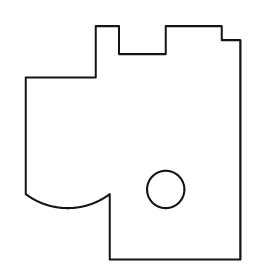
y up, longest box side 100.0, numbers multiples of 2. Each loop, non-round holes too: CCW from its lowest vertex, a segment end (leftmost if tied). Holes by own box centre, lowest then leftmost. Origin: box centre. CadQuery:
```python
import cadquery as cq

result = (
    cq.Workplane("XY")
    .moveTo(-10.0, -50.0)
    .lineTo(46.0, -50.0)
    .lineTo(46.0, 44.0)
    .lineTo(38.0, 44.0)
    .lineTo(38.0, 50.0)
    .lineTo(14.0, 50.0)
    .lineTo(14.0, 38.0)
    .lineTo(-6.0, 38.0)
    .lineTo(-6.0, 50.0)
    .lineTo(-16.0, 50.0)
    .lineTo(-16.0, 28.0)
    .lineTo(-46.0, 28.0)
    .lineTo(-46.0, -22.0)
    .threePointArc((-28.0, -28.0), (-10.0, -22.0))
    .close()
    .moveTo(14.0, -20.0)
    .circle(8.0)
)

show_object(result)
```